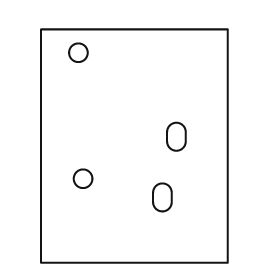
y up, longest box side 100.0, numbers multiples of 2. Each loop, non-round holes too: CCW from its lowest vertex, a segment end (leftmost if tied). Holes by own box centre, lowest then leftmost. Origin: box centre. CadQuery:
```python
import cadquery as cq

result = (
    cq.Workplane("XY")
    .moveTo(-40.0, -50.0)
    .lineTo(40.0, -50.0)
    .lineTo(40.0, 50.0)
    .lineTo(-40.0, 50.0)
    .close()
    .moveTo(8.0, -24.0)
    .threePointArc((12.0, -28.0), (16.0, -24.0))
    .lineTo(16.0, -20.0)
    .threePointArc((12.0, -16.0), (8.0, -20.0))
    .close()
    .moveTo(-22.0, -14.0)
    .circle(4.0)
    .moveTo(14.0, 2.0)
    .threePointArc((18.0, -2.0), (22.0, 2.0))
    .lineTo(22.0, 6.0)
    .threePointArc((18.0, 10.0), (14.0, 6.0))
    .close()
    .moveTo(-24.0, 40.0)
    .circle(4.0)
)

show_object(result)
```